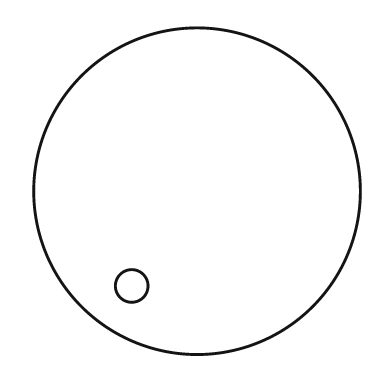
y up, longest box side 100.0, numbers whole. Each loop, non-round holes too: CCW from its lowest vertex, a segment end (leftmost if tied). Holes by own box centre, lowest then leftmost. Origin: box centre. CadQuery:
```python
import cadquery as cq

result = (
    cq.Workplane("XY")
    .moveTo(0.0, 0.0)
    .circle(50.0)
    .moveTo(-20.0, -29.0)
    .circle(5.0)
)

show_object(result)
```